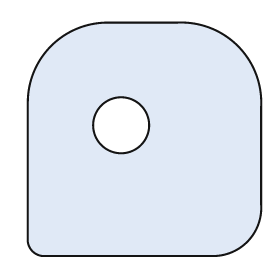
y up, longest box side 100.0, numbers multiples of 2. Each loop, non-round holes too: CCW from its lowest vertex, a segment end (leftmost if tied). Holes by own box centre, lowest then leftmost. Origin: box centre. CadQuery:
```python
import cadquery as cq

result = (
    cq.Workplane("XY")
    .moveTo(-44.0, -50.0)
    .lineTo(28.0, -50.0)
    .threePointArc((44.0, -44.0), (50.0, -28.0))
    .lineTo(50.0, 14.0)
    .threePointArc((40.0, 40.0), (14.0, 50.0))
    .lineTo(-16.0, 50.0)
    .threePointArc((-40.0, 40.0), (-50.0, 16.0))
    .lineTo(-50.0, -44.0)
    .threePointArc((-48.0, -48.0), (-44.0, -50.0))
    .close()
    .moveTo(-10.0, 6.0)
    .circle(12.0)
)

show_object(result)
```